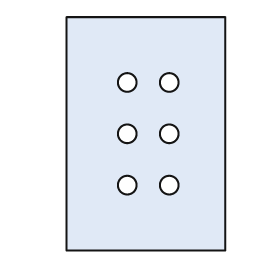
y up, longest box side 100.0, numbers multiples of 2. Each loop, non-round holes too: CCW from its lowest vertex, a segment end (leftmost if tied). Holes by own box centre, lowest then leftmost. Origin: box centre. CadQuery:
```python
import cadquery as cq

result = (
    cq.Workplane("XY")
    .moveTo(-34.0, -50.0)
    .lineTo(34.0, -50.0)
    .lineTo(34.0, 50.0)
    .lineTo(-34.0, 50.0)
    .close()
    .moveTo(-8.0, -22.0)
    .circle(4.0)
    .moveTo(10.0, -22.0)
    .circle(4.0)
    .moveTo(-8.0, 0.0)
    .circle(4.0)
    .moveTo(10.0, 0.0)
    .circle(4.0)
    .moveTo(-8.0, 22.0)
    .circle(4.0)
    .moveTo(10.0, 22.0)
    .circle(4.0)
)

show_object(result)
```